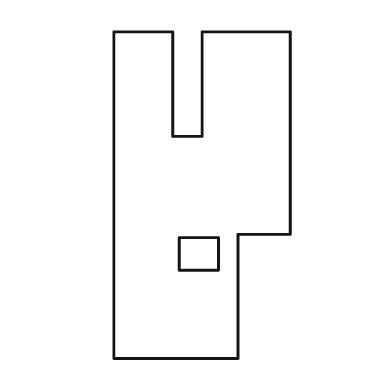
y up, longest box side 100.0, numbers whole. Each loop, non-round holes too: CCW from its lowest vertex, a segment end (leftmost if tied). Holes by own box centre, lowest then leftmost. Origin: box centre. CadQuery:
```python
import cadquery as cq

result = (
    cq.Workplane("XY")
    .moveTo(-27.0, -50.0)
    .lineTo(11.0, -50.0)
    .lineTo(11.0, -12.0)
    .lineTo(27.0, -12.0)
    .lineTo(27.0, 50.0)
    .lineTo(0.0, 50.0)
    .lineTo(0.0, 18.0)
    .lineTo(-9.0, 18.0)
    .lineTo(-9.0, 50.0)
    .lineTo(-27.0, 50.0)
    .close()
    .moveTo(-7.0, -23.0)
    .lineTo(5.0, -23.0)
    .lineTo(5.0, -13.0)
    .lineTo(-7.0, -13.0)
    .close()
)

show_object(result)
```